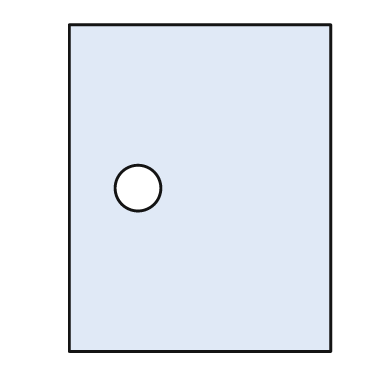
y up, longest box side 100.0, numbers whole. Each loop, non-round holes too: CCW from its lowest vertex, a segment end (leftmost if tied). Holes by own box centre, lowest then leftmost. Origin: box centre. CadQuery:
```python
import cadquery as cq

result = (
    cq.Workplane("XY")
    .moveTo(-40.0, -50.0)
    .lineTo(40.0, -50.0)
    .lineTo(40.0, 50.0)
    .lineTo(-40.0, 50.0)
    .close()
    .moveTo(-19.0, 0.0)
    .circle(7.0)
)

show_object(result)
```